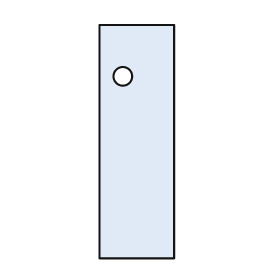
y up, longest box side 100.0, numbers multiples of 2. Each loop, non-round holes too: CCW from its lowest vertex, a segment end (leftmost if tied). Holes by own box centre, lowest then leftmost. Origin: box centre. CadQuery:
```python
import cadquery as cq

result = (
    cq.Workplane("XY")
    .moveTo(-16.0, -50.0)
    .lineTo(16.0, -50.0)
    .lineTo(16.0, 50.0)
    .lineTo(-16.0, 50.0)
    .close()
    .moveTo(-6.0, 28.0)
    .circle(4.0)
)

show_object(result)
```